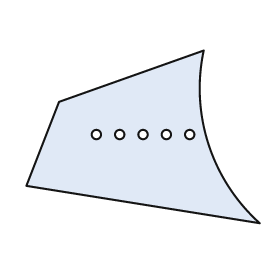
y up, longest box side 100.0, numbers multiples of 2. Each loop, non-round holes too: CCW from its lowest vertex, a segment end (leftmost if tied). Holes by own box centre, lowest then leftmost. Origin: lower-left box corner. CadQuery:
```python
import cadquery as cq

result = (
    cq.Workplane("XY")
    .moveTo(100.0, 0.0)
    .threePointArc((78.0, 34.0), (76.0, 74.0))
    .lineTo(14.0, 52.0)
    .lineTo(0.0, 16.0)
    .close()
    .moveTo(30.0, 38.0)
    .circle(2.0)
    .moveTo(40.0, 38.0)
    .circle(2.0)
    .moveTo(50.0, 38.0)
    .circle(2.0)
    .moveTo(60.0, 38.0)
    .circle(2.0)
    .moveTo(70.0, 38.0)
    .circle(2.0)
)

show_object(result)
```